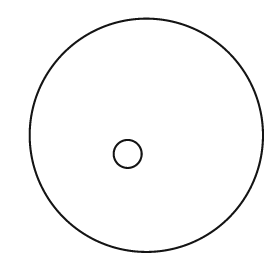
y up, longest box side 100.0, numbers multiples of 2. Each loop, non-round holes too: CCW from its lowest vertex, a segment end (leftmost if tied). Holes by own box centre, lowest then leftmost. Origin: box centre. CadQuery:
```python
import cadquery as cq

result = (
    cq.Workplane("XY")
    .moveTo(0.0, 0.0)
    .circle(50.0)
    .moveTo(-8.0, -8.0)
    .circle(6.0)
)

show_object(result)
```